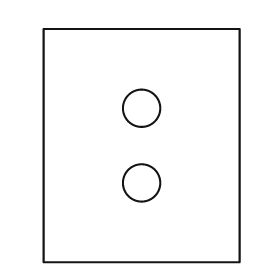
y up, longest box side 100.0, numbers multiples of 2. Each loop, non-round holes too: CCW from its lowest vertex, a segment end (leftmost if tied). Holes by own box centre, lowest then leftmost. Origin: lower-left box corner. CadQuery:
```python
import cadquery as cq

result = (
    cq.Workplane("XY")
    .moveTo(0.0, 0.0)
    .lineTo(84.0, 0.0)
    .lineTo(84.0, 100.0)
    .lineTo(0.0, 100.0)
    .close()
    .moveTo(42.0, 34.0)
    .circle(8.0)
    .moveTo(42.0, 66.0)
    .circle(8.0)
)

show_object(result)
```